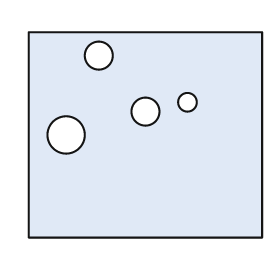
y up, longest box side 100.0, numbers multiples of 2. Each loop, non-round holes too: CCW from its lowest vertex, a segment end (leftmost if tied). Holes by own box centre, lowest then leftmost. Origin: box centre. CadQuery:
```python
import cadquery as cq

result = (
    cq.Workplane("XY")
    .moveTo(-50.0, -44.0)
    .lineTo(50.0, -44.0)
    .lineTo(50.0, 44.0)
    .lineTo(-50.0, 44.0)
    .close()
    .moveTo(-34.0, 0.0)
    .circle(8.0)
    .moveTo(0.0, 10.0)
    .circle(6.0)
    .moveTo(18.0, 14.0)
    .circle(4.0)
    .moveTo(-20.0, 34.0)
    .circle(6.0)
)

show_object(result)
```